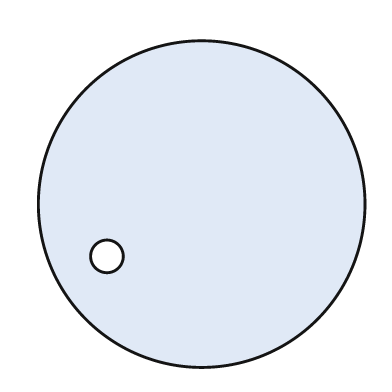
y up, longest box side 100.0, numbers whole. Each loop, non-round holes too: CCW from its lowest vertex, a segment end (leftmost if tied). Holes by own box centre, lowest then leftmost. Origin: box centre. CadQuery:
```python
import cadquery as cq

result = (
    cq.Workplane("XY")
    .moveTo(0.0, 0.0)
    .circle(50.0)
    .moveTo(-29.0, -16.0)
    .circle(5.0)
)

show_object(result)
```